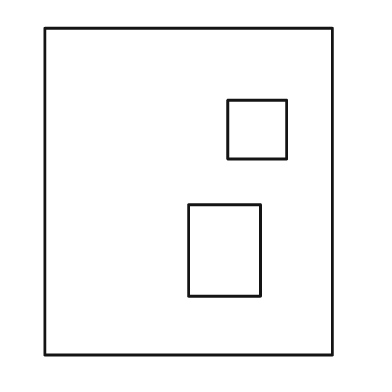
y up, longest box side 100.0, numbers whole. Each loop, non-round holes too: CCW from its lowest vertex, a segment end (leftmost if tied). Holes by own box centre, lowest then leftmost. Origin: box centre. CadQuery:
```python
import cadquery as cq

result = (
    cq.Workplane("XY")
    .moveTo(-44.0, -50.0)
    .lineTo(44.0, -50.0)
    .lineTo(44.0, 50.0)
    .lineTo(-44.0, 50.0)
    .close()
    .moveTo(0.0, -32.0)
    .lineTo(22.0, -32.0)
    .lineTo(22.0, -4.0)
    .lineTo(0.0, -4.0)
    .close()
    .moveTo(12.0, 10.0)
    .lineTo(30.0, 10.0)
    .lineTo(30.0, 28.0)
    .lineTo(12.0, 28.0)
    .close()
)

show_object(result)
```